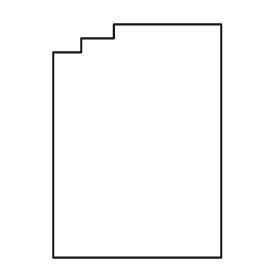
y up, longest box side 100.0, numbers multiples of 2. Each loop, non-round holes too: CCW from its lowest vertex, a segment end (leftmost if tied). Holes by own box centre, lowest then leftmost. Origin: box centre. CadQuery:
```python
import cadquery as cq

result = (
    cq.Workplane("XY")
    .moveTo(-36.0, -50.0)
    .lineTo(36.0, -50.0)
    .lineTo(36.0, 50.0)
    .lineTo(-10.0, 50.0)
    .lineTo(-10.0, 44.0)
    .lineTo(-24.0, 44.0)
    .lineTo(-24.0, 38.0)
    .lineTo(-36.0, 38.0)
    .close()
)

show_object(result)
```